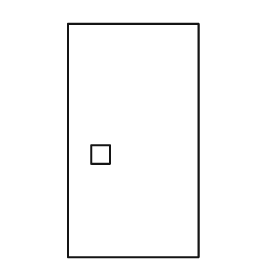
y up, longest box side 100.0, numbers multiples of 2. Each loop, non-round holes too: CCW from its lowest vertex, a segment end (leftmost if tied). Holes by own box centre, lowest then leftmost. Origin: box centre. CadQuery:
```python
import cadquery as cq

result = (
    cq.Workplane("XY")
    .moveTo(-28.0, -50.0)
    .lineTo(28.0, -50.0)
    .lineTo(28.0, 50.0)
    .lineTo(-28.0, 50.0)
    .close()
    .moveTo(-18.0, -10.0)
    .lineTo(-10.0, -10.0)
    .lineTo(-10.0, -2.0)
    .lineTo(-18.0, -2.0)
    .close()
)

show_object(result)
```